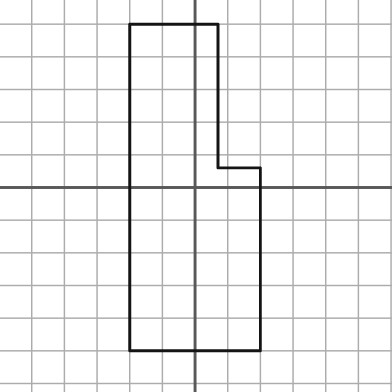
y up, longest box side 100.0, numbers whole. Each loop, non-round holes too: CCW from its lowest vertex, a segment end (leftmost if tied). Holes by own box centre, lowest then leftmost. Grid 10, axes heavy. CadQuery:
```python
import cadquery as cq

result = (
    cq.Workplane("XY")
    .moveTo(-20.0, -50.0)
    .lineTo(20.0, -50.0)
    .lineTo(20.0, 6.0)
    .lineTo(7.0, 6.0)
    .lineTo(7.0, 50.0)
    .lineTo(-20.0, 50.0)
    .close()
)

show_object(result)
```